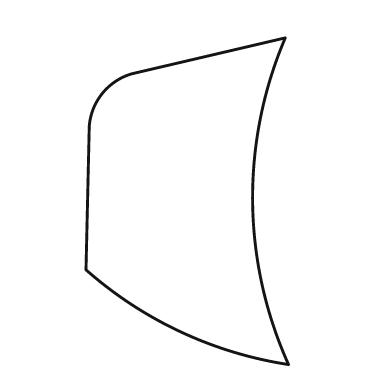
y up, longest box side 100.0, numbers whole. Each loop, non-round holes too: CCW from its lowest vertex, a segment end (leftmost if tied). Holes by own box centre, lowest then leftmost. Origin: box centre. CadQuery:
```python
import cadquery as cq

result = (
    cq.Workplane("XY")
    .moveTo(31.0, -50.0)
    .threePointArc((20.0, 0.0), (30.0, 50.0))
    .lineTo(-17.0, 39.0)
    .threePointArc((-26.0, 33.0), (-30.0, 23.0))
    .lineTo(-31.0, -21.0)
    .threePointArc((-2.0, -40.0), (31.0, -50.0))
    .close()
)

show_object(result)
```